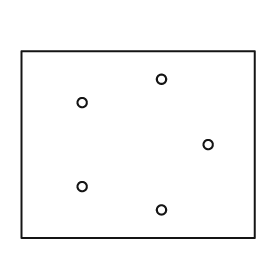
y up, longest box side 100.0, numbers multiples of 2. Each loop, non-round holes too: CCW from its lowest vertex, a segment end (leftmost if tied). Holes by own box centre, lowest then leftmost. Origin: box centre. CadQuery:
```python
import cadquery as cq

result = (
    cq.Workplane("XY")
    .moveTo(-50.0, -40.0)
    .lineTo(50.0, -40.0)
    .lineTo(50.0, 40.0)
    .lineTo(-50.0, 40.0)
    .close()
    .moveTo(10.0, -28.0)
    .circle(2.0)
    .moveTo(-24.0, -18.0)
    .circle(2.0)
    .moveTo(30.0, 0.0)
    .circle(2.0)
    .moveTo(-24.0, 18.0)
    .circle(2.0)
    .moveTo(10.0, 28.0)
    .circle(2.0)
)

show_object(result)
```